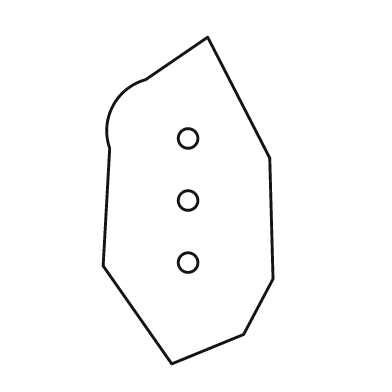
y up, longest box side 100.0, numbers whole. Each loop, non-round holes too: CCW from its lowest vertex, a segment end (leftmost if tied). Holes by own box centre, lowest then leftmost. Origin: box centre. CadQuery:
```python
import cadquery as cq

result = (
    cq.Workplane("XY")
    .moveTo(-5.0, -50.0)
    .lineTo(17.0, -41.0)
    .lineTo(26.0, -24.0)
    .lineTo(25.0, 13.0)
    .lineTo(6.0, 50.0)
    .lineTo(-13.0, 37.0)
    .threePointArc((-23.0, 29.0), (-24.0, 16.0))
    .lineTo(-26.0, -20.0)
    .close()
    .moveTo(0.0, -19.0)
    .circle(3.0)
    .moveTo(0.0, 0.0)
    .circle(3.0)
    .moveTo(0.0, 19.0)
    .circle(3.0)
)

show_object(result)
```